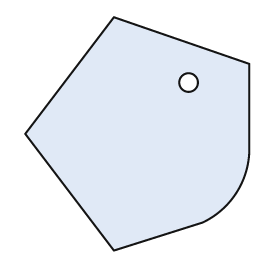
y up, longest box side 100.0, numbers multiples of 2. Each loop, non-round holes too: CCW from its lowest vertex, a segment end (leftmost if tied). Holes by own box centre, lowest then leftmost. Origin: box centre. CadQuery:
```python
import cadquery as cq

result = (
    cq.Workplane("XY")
    .moveTo(-10.0, -50.0)
    .lineTo(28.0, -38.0)
    .threePointArc((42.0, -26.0), (48.0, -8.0))
    .lineTo(48.0, 30.0)
    .lineTo(-10.0, 50.0)
    .lineTo(-48.0, 0.0)
    .close()
    .moveTo(22.0, 22.0)
    .circle(4.0)
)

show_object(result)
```